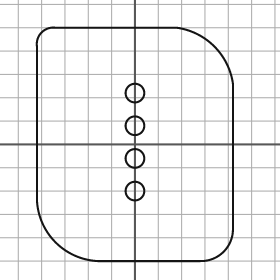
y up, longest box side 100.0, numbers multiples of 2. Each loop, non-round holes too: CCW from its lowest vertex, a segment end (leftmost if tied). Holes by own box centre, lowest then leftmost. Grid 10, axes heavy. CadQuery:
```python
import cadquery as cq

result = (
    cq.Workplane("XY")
    .moveTo(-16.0, -50.0)
    .lineTo(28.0, -50.0)
    .threePointArc((38.0, -46.0), (42.0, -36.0))
    .lineTo(42.0, 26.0)
    .threePointArc((34.0, 42.0), (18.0, 50.0))
    .lineTo(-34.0, 50.0)
    .threePointArc((-40.0, 48.0), (-42.0, 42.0))
    .lineTo(-42.0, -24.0)
    .threePointArc((-34.0, -42.0), (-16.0, -50.0))
    .close()
    .moveTo(0.0, -20.0)
    .circle(4.0)
    .moveTo(0.0, -6.0)
    .circle(4.0)
    .moveTo(0.0, 8.0)
    .circle(4.0)
    .moveTo(0.0, 22.0)
    .circle(4.0)
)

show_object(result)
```